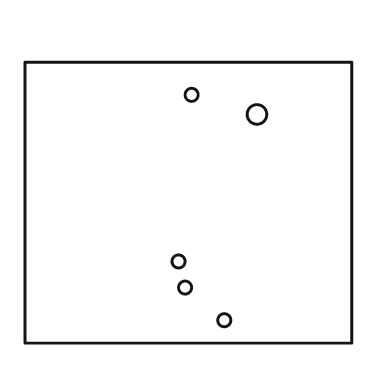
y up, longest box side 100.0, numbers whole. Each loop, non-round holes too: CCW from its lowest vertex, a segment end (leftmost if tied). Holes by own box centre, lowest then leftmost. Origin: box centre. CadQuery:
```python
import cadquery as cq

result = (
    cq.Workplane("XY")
    .moveTo(-50.0, -43.0)
    .lineTo(50.0, -43.0)
    .lineTo(50.0, 43.0)
    .lineTo(-50.0, 43.0)
    .close()
    .moveTo(11.0, -36.0)
    .circle(2.0)
    .moveTo(-1.0, -26.0)
    .circle(2.0)
    .moveTo(-3.0, -18.0)
    .circle(2.0)
    .moveTo(21.0, 27.0)
    .circle(3.0)
    .moveTo(1.0, 33.0)
    .circle(2.0)
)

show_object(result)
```